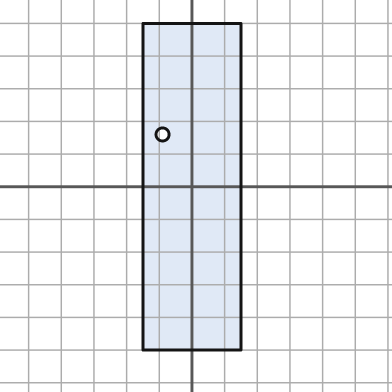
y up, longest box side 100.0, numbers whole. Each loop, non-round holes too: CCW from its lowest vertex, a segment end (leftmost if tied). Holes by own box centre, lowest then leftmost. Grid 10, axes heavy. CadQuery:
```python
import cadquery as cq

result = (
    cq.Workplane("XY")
    .moveTo(-15.0, -50.0)
    .lineTo(15.0, -50.0)
    .lineTo(15.0, 50.0)
    .lineTo(-15.0, 50.0)
    .close()
    .moveTo(-9.0, 16.0)
    .circle(2.0)
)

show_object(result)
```